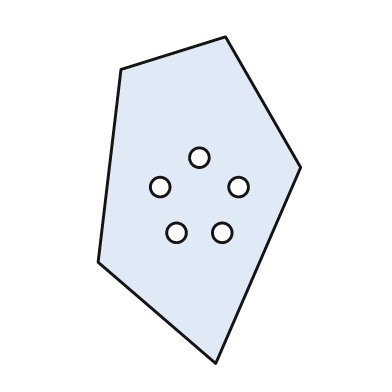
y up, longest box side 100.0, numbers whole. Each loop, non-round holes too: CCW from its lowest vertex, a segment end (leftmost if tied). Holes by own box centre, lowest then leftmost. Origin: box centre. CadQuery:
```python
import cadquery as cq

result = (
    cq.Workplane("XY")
    .moveTo(5.0, -50.0)
    .lineTo(31.0, 10.0)
    .lineTo(8.0, 50.0)
    .lineTo(-24.0, 40.0)
    .lineTo(-31.0, -19.0)
    .close()
    .moveTo(-7.0, -10.0)
    .circle(3.0)
    .moveTo(7.0, -10.0)
    .circle(3.0)
    .moveTo(-12.0, 4.0)
    .circle(3.0)
    .moveTo(12.0, 4.0)
    .circle(3.0)
    .moveTo(0.0, 13.0)
    .circle(3.0)
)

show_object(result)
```